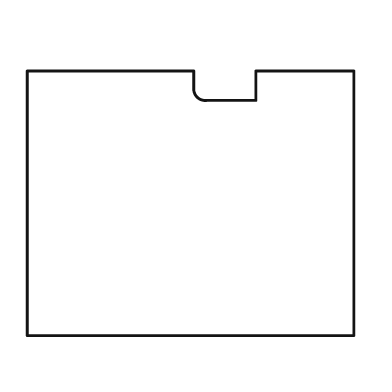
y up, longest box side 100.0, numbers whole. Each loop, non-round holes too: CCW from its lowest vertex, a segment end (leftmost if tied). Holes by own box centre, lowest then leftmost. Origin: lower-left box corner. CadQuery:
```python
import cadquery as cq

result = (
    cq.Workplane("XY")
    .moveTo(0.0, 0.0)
    .lineTo(100.0, 0.0)
    .lineTo(100.0, 81.0)
    .lineTo(70.0, 81.0)
    .lineTo(70.0, 72.0)
    .lineTo(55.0, 72.0)
    .threePointArc((52.0, 73.0), (51.0, 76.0))
    .lineTo(51.0, 81.0)
    .lineTo(0.0, 81.0)
    .close()
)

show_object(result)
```